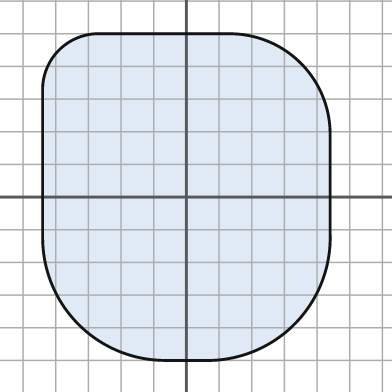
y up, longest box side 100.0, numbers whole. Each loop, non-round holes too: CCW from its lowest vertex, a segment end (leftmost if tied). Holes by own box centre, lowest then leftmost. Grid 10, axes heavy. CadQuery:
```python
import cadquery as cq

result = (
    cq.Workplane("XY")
    .moveTo(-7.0, -50.0)
    .lineTo(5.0, -50.0)
    .threePointArc((33.0, -39.0), (44.0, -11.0))
    .lineTo(44.0, 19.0)
    .threePointArc((35.0, 41.0), (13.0, 50.0))
    .lineTo(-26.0, 50.0)
    .threePointArc((-39.0, 45.0), (-44.0, 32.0))
    .lineTo(-44.0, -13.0)
    .threePointArc((-33.0, -39.0), (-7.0, -50.0))
    .close()
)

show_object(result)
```